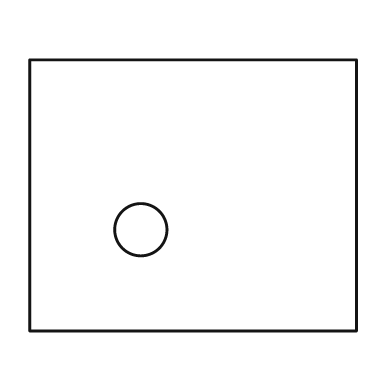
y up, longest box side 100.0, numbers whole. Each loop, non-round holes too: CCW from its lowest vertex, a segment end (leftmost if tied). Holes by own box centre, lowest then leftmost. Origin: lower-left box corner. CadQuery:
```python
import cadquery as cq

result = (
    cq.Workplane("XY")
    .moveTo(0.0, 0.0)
    .lineTo(100.0, 0.0)
    .lineTo(100.0, 83.0)
    .lineTo(0.0, 83.0)
    .close()
    .moveTo(34.0, 31.0)
    .circle(8.0)
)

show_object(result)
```